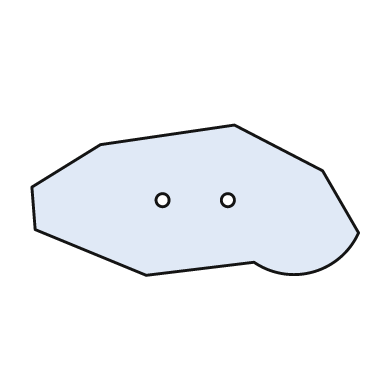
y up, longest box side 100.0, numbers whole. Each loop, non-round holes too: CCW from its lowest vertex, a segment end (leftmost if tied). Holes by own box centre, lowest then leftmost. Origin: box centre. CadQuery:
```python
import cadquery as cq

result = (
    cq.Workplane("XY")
    .moveTo(-15.0, -23.0)
    .lineTo(18.0, -19.0)
    .threePointArc((36.0, -22.0), (50.0, -10.0))
    .lineTo(39.0, 9.0)
    .lineTo(12.0, 23.0)
    .lineTo(-29.0, 17.0)
    .lineTo(-50.0, 4.0)
    .lineTo(-49.0, -9.0)
    .close()
    .moveTo(-10.0, 0.0)
    .circle(2.0)
    .moveTo(10.0, 0.0)
    .circle(2.0)
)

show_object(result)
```